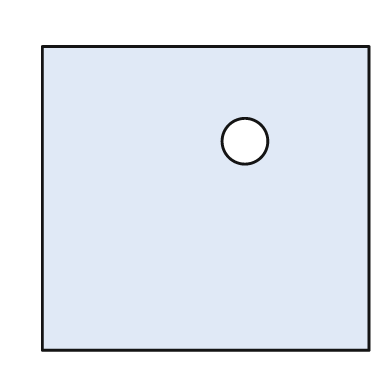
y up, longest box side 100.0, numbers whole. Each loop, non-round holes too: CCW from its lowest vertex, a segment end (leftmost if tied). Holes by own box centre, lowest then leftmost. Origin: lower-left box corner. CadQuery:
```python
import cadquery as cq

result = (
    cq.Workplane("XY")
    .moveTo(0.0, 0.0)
    .lineTo(100.0, 0.0)
    .lineTo(100.0, 93.0)
    .lineTo(0.0, 93.0)
    .close()
    .moveTo(62.0, 64.0)
    .circle(7.0)
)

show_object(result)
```